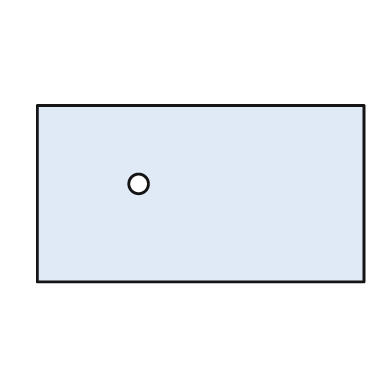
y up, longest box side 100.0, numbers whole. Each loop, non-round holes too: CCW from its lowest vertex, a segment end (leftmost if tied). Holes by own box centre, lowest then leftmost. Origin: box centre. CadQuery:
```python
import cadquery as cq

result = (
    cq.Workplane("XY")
    .moveTo(-50.0, -27.0)
    .lineTo(50.0, -27.0)
    .lineTo(50.0, 27.0)
    .lineTo(-50.0, 27.0)
    .close()
    .moveTo(-19.0, 3.0)
    .circle(3.0)
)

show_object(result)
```